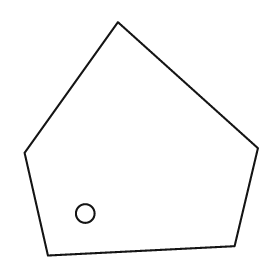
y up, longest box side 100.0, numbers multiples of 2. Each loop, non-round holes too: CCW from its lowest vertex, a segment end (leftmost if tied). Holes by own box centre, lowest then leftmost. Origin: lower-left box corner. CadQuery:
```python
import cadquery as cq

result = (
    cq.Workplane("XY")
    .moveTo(10.0, 0.0)
    .lineTo(90.0, 4.0)
    .lineTo(100.0, 46.0)
    .lineTo(40.0, 100.0)
    .lineTo(0.0, 44.0)
    .close()
    .moveTo(26.0, 18.0)
    .circle(4.0)
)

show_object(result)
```